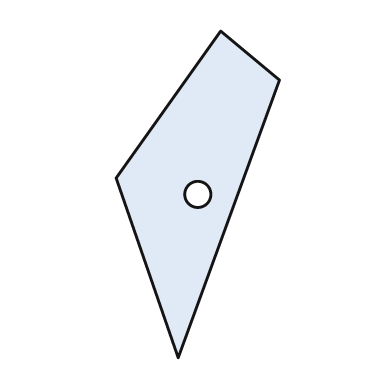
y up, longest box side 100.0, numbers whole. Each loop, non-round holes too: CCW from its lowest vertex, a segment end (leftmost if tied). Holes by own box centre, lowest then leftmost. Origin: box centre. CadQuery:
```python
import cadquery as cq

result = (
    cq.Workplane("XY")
    .moveTo(-6.0, -50.0)
    .lineTo(25.0, 35.0)
    .lineTo(7.0, 50.0)
    .lineTo(-25.0, 5.0)
    .close()
    .moveTo(0.0, 0.0)
    .circle(4.0)
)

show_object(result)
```